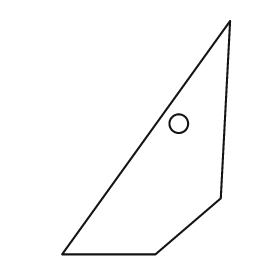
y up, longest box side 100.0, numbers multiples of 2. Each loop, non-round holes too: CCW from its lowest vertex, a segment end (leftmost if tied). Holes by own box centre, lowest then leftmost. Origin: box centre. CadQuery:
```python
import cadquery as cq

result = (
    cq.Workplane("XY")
    .moveTo(-36.0, -50.0)
    .lineTo(4.0, -50.0)
    .lineTo(32.0, -26.0)
    .lineTo(36.0, 50.0)
    .close()
    .moveTo(14.0, 6.0)
    .circle(4.0)
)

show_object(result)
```